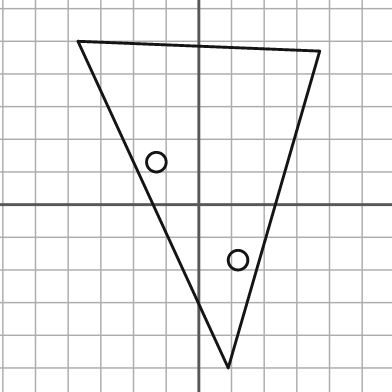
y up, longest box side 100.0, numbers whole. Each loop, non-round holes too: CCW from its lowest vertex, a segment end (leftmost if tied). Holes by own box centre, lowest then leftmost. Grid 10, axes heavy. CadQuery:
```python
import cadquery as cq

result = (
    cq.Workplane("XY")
    .moveTo(9.0, -50.0)
    .lineTo(37.0, 47.0)
    .lineTo(-37.0, 50.0)
    .close()
    .moveTo(12.0, -17.0)
    .circle(3.0)
    .moveTo(-13.0, 13.0)
    .circle(3.0)
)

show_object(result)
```